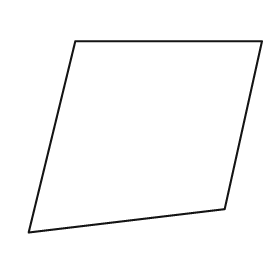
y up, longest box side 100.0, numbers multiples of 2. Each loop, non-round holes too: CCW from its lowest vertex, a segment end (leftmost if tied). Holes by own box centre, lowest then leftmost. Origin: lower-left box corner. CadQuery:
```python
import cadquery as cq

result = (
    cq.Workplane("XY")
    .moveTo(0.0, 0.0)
    .lineTo(84.0, 10.0)
    .lineTo(100.0, 82.0)
    .lineTo(20.0, 82.0)
    .close()
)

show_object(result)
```